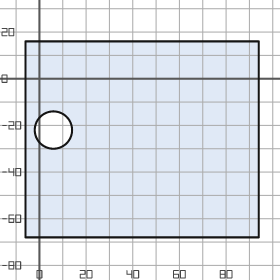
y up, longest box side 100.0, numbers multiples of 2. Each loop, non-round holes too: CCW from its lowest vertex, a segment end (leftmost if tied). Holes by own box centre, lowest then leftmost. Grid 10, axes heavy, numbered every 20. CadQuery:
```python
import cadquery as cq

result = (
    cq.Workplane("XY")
    .moveTo(-6.0, -68.0)
    .lineTo(94.0, -68.0)
    .lineTo(94.0, 16.0)
    .lineTo(-6.0, 16.0)
    .close()
    .moveTo(6.0, -22.0)
    .circle(8.0)
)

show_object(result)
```